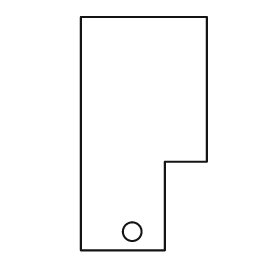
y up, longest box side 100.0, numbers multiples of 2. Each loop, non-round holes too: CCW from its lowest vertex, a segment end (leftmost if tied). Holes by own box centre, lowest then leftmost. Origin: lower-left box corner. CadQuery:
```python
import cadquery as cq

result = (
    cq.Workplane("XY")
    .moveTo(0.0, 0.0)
    .lineTo(36.0, 0.0)
    .lineTo(36.0, 38.0)
    .lineTo(54.0, 38.0)
    .lineTo(54.0, 100.0)
    .lineTo(0.0, 100.0)
    .close()
    .moveTo(22.0, 8.0)
    .circle(4.0)
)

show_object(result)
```